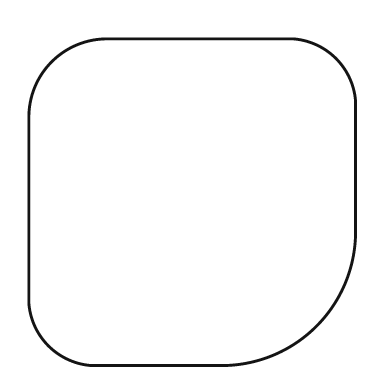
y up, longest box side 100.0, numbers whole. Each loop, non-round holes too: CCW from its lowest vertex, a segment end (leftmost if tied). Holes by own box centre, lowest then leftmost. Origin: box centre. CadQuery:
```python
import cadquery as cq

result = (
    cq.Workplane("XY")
    .moveTo(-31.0, -50.0)
    .lineTo(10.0, -50.0)
    .threePointArc((38.0, -38.0), (50.0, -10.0))
    .lineTo(50.0, 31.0)
    .threePointArc((44.0, 44.0), (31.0, 50.0))
    .lineTo(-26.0, 50.0)
    .threePointArc((-43.0, 43.0), (-50.0, 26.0))
    .lineTo(-50.0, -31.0)
    .threePointArc((-44.0, -44.0), (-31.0, -50.0))
    .close()
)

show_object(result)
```